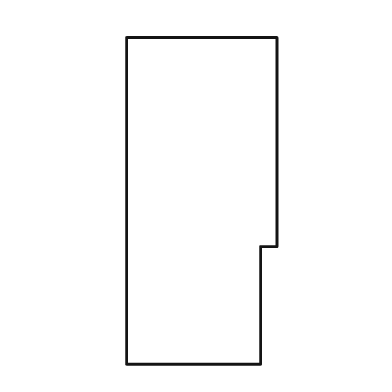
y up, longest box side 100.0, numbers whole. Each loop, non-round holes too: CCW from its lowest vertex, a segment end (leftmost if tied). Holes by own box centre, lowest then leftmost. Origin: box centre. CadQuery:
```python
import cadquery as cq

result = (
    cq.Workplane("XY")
    .moveTo(-23.0, -50.0)
    .lineTo(18.0, -50.0)
    .lineTo(18.0, -14.0)
    .lineTo(23.0, -14.0)
    .lineTo(23.0, 50.0)
    .lineTo(-23.0, 50.0)
    .close()
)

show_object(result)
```